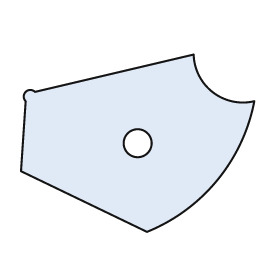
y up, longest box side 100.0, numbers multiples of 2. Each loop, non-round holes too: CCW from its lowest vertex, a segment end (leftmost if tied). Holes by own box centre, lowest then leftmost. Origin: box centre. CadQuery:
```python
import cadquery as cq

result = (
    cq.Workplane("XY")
    .moveTo(4.0, -38.0)
    .threePointArc((34.0, -16.0), (50.0, 18.0))
    .threePointArc((32.0, 22.0), (24.0, 38.0))
    .lineTo(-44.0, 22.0)
    .threePointArc((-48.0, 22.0), (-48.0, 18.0))
    .lineTo(-50.0, -12.0)
    .close()
    .moveTo(0.0, 0.0)
    .circle(6.0)
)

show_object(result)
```